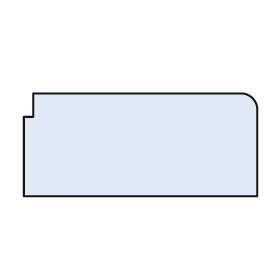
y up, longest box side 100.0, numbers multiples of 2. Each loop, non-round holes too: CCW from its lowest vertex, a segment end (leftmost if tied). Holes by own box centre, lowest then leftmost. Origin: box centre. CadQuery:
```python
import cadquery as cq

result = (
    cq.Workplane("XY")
    .moveTo(-50.0, -22.0)
    .lineTo(50.0, -22.0)
    .lineTo(50.0, 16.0)
    .threePointArc((48.0, 20.0), (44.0, 22.0))
    .lineTo(-46.0, 22.0)
    .lineTo(-46.0, 12.0)
    .lineTo(-50.0, 12.0)
    .close()
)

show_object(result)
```